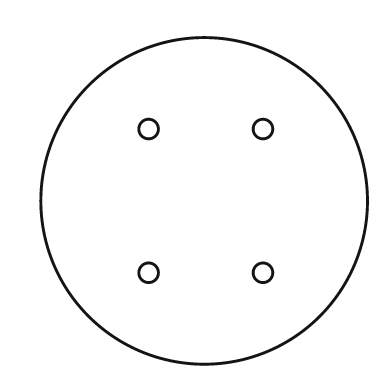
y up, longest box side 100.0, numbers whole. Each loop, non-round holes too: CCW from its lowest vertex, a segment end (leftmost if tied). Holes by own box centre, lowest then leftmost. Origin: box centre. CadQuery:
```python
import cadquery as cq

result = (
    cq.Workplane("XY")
    .moveTo(0.0, 0.0)
    .circle(50.0)
    .moveTo(-17.0, -22.0)
    .circle(3.0)
    .moveTo(18.0, -22.0)
    .circle(3.0)
    .moveTo(-17.0, 22.0)
    .circle(3.0)
    .moveTo(18.0, 22.0)
    .circle(3.0)
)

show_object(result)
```